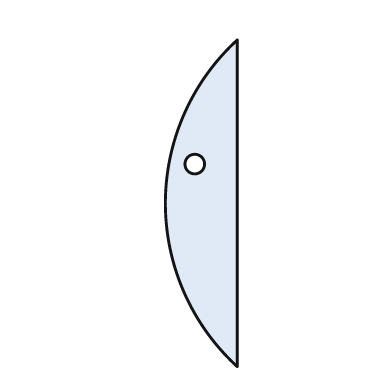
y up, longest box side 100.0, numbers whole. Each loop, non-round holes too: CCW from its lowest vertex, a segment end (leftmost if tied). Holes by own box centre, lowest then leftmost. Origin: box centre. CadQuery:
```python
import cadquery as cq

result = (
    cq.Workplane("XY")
    .moveTo(11.0, -50.0)
    .lineTo(11.0, 50.0)
    .threePointArc((-11.0, 0.0), (11.0, -50.0))
    .close()
    .moveTo(-2.0, 12.0)
    .circle(3.0)
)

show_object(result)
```